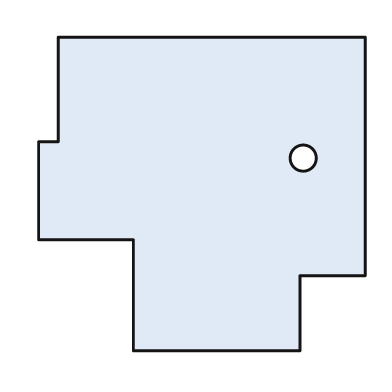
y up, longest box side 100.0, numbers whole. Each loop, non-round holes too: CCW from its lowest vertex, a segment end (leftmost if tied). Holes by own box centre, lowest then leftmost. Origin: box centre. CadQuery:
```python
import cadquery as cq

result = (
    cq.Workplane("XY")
    .moveTo(-21.0, -48.0)
    .lineTo(30.0, -48.0)
    .lineTo(30.0, -25.0)
    .lineTo(50.0, -25.0)
    .lineTo(50.0, 48.0)
    .lineTo(-44.0, 48.0)
    .lineTo(-44.0, 16.0)
    .lineTo(-50.0, 16.0)
    .lineTo(-50.0, -14.0)
    .lineTo(-21.0, -14.0)
    .close()
    .moveTo(31.0, 11.0)
    .circle(4.0)
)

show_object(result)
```